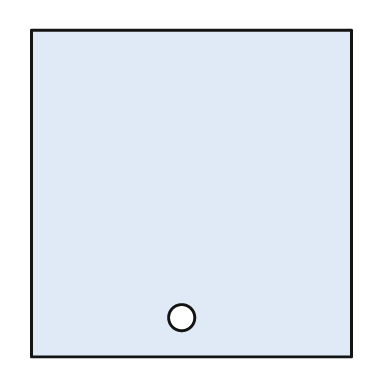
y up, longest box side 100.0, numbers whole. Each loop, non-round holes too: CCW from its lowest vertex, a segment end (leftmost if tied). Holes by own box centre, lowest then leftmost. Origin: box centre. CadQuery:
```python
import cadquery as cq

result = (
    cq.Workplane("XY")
    .moveTo(-49.0, -50.0)
    .lineTo(49.0, -50.0)
    .lineTo(49.0, 50.0)
    .lineTo(-49.0, 50.0)
    .close()
    .moveTo(-3.0, -38.0)
    .circle(4.0)
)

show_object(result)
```